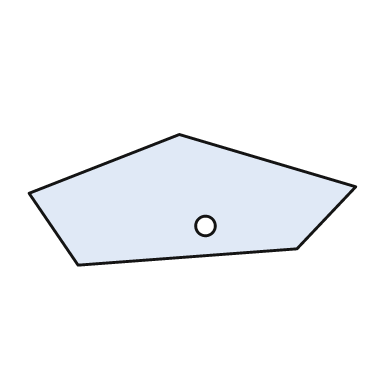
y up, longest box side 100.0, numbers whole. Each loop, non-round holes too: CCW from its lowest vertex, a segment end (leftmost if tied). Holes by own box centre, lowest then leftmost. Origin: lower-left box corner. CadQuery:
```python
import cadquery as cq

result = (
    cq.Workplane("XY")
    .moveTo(15.0, 0.0)
    .lineTo(82.0, 5.0)
    .lineTo(100.0, 24.0)
    .lineTo(46.0, 40.0)
    .lineTo(0.0, 22.0)
    .close()
    .moveTo(54.0, 12.0)
    .circle(3.0)
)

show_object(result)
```